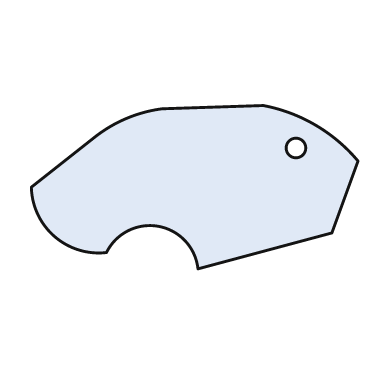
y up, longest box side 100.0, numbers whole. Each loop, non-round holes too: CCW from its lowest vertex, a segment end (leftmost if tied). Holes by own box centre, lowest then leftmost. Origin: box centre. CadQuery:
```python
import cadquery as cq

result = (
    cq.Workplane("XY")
    .moveTo(1.0, -25.0)
    .lineTo(42.0, -14.0)
    .lineTo(50.0, 8.0)
    .threePointArc((37.0, 19.0), (21.0, 25.0))
    .lineTo(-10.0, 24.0)
    .threePointArc((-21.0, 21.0), (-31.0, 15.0))
    .lineTo(-50.0, 0.0)
    .threePointArc((-43.0, -15.0), (-27.0, -20.0))
    .threePointArc((-11.0, -12.0), (1.0, -25.0))
    .close()
    .moveTo(31.0, 12.0)
    .circle(3.0)
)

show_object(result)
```